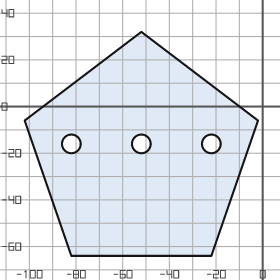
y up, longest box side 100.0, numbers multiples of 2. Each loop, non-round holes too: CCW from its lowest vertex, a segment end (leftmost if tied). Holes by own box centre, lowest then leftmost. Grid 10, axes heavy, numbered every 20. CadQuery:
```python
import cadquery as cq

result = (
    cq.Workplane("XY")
    .moveTo(-82.0, -64.0)
    .lineTo(-22.0, -64.0)
    .lineTo(-2.0, -6.0)
    .lineTo(-52.0, 32.0)
    .lineTo(-102.0, -6.0)
    .close()
    .moveTo(-82.0, -16.0)
    .circle(4.0)
    .moveTo(-52.0, -16.0)
    .circle(4.0)
    .moveTo(-22.0, -16.0)
    .circle(4.0)
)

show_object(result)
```